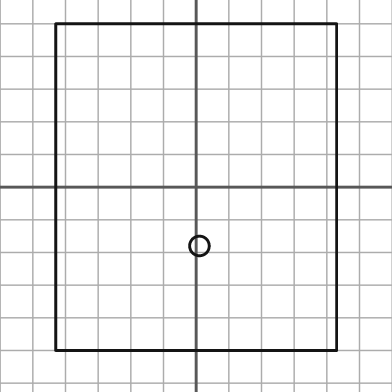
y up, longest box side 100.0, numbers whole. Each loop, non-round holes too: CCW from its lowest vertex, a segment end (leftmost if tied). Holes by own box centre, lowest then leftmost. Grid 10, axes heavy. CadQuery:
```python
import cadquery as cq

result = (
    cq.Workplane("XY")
    .moveTo(-43.0, -50.0)
    .lineTo(43.0, -50.0)
    .lineTo(43.0, 50.0)
    .lineTo(-43.0, 50.0)
    .close()
    .moveTo(1.0, -18.0)
    .circle(3.0)
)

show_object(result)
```